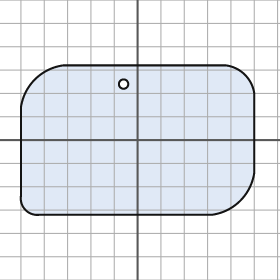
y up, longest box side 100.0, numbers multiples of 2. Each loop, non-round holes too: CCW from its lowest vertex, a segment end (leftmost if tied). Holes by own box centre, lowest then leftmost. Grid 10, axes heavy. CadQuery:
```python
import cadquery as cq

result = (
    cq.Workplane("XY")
    .moveTo(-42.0, -32.0)
    .lineTo(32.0, -32.0)
    .threePointArc((44.0, -26.0), (50.0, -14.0))
    .lineTo(50.0, 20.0)
    .threePointArc((46.0, 28.0), (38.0, 32.0))
    .lineTo(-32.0, 32.0)
    .threePointArc((-44.0, 26.0), (-50.0, 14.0))
    .lineTo(-50.0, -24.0)
    .threePointArc((-48.0, -30.0), (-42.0, -32.0))
    .close()
    .moveTo(-6.0, 24.0)
    .circle(2.0)
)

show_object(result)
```